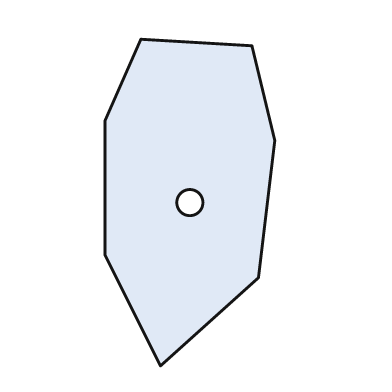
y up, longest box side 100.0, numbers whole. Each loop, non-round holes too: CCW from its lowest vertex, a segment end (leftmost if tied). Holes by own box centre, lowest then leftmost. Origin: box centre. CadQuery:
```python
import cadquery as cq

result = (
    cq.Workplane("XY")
    .moveTo(-9.0, -50.0)
    .lineTo(21.0, -23.0)
    .lineTo(26.0, 19.0)
    .lineTo(19.0, 48.0)
    .lineTo(-15.0, 50.0)
    .lineTo(-26.0, 25.0)
    .lineTo(-26.0, -16.0)
    .close()
    .moveTo(0.0, 0.0)
    .circle(4.0)
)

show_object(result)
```